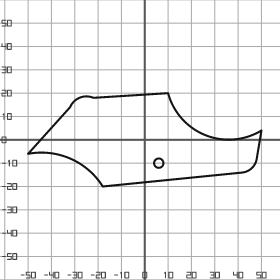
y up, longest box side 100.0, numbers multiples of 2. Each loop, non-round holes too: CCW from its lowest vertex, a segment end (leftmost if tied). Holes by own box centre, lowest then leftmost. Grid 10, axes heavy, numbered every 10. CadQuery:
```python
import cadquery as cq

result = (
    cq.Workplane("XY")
    .moveTo(-18.0, -20.0)
    .lineTo(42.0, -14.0)
    .threePointArc((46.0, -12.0), (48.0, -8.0))
    .lineTo(50.0, 4.0)
    .threePointArc((26.0, 2.0), (10.0, 20.0))
    .lineTo(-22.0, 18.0)
    .threePointArc((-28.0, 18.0), (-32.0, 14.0))
    .lineTo(-50.0, -6.0)
    .threePointArc((-32.0, -8.0), (-18.0, -20.0))
    .close()
    .moveTo(6.0, -10.0)
    .circle(2.0)
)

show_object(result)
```